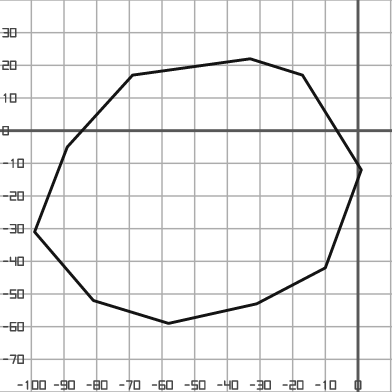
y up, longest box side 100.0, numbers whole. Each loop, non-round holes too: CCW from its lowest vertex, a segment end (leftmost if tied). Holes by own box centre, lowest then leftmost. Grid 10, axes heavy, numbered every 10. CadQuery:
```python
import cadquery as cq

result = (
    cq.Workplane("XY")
    .moveTo(-58.0, -59.0)
    .lineTo(-31.0, -53.0)
    .lineTo(-10.0, -42.0)
    .lineTo(1.0, -12.0)
    .lineTo(-17.0, 17.0)
    .lineTo(-33.0, 22.0)
    .lineTo(-69.0, 17.0)
    .lineTo(-89.0, -5.0)
    .lineTo(-99.0, -31.0)
    .lineTo(-81.0, -52.0)
    .close()
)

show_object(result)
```